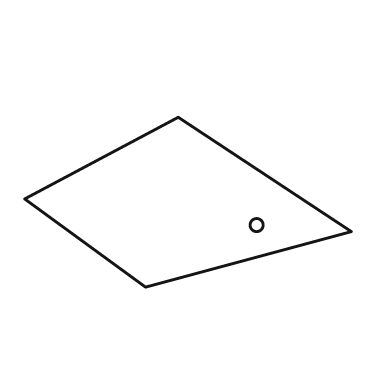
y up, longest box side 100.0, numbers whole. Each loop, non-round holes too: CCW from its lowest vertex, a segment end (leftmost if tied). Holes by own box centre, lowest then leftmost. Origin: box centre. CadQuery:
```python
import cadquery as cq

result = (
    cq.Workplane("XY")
    .moveTo(-13.0, -26.0)
    .lineTo(50.0, -9.0)
    .lineTo(-3.0, 26.0)
    .lineTo(-50.0, 1.0)
    .close()
    .moveTo(21.0, -7.0)
    .circle(2.0)
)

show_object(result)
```